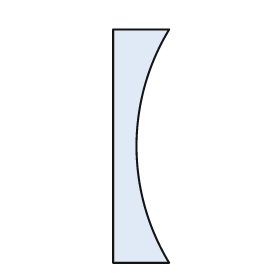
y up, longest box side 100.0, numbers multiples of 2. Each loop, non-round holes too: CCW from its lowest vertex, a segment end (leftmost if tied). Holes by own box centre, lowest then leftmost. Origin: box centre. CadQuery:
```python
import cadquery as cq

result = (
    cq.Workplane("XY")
    .moveTo(-12.0, -50.0)
    .lineTo(12.0, -50.0)
    .threePointArc((-2.0, 0.0), (12.0, 50.0))
    .lineTo(-12.0, 50.0)
    .close()
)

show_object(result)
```